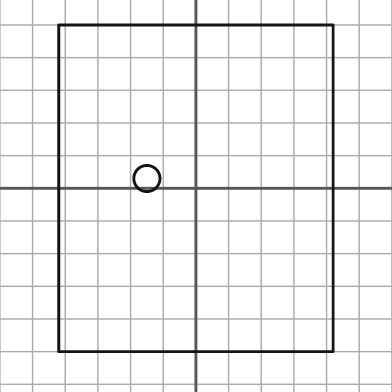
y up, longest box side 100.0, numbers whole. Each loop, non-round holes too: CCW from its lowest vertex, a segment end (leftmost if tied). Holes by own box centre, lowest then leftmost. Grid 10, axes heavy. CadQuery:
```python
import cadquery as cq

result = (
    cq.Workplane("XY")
    .moveTo(-42.0, -50.0)
    .lineTo(42.0, -50.0)
    .lineTo(42.0, 50.0)
    .lineTo(-42.0, 50.0)
    .close()
    .moveTo(-15.0, 3.0)
    .circle(4.0)
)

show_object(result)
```